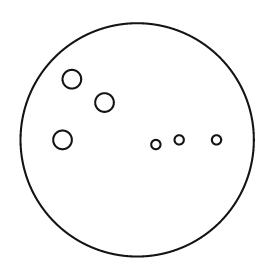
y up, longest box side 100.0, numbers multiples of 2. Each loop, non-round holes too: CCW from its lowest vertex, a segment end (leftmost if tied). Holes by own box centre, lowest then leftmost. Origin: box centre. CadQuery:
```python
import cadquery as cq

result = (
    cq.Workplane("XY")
    .moveTo(0.0, 0.0)
    .circle(50.0)
    .moveTo(8.0, -2.0)
    .circle(2.0)
    .moveTo(-32.0, 0.0)
    .circle(4.0)
    .moveTo(18.0, 0.0)
    .circle(2.0)
    .moveTo(34.0, 0.0)
    .circle(2.0)
    .moveTo(-14.0, 16.0)
    .circle(4.0)
    .moveTo(-28.0, 26.0)
    .circle(4.0)
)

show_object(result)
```